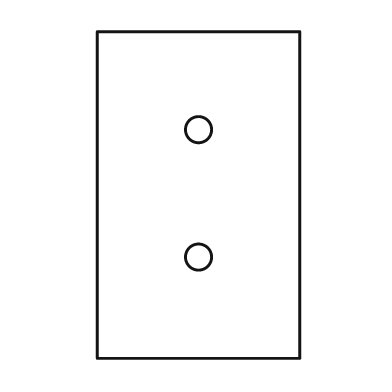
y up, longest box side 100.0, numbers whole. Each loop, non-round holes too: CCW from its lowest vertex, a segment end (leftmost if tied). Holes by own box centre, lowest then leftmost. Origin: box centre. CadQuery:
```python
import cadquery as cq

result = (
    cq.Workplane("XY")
    .moveTo(-31.0, -50.0)
    .lineTo(31.0, -50.0)
    .lineTo(31.0, 50.0)
    .lineTo(-31.0, 50.0)
    .close()
    .moveTo(0.0, -19.0)
    .circle(4.0)
    .moveTo(0.0, 20.0)
    .circle(4.0)
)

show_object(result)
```